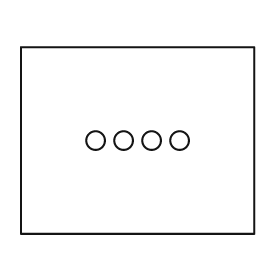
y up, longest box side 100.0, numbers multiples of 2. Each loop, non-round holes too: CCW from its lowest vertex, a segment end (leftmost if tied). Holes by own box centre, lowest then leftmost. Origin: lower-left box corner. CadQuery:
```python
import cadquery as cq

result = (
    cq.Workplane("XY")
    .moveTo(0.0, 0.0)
    .lineTo(100.0, 0.0)
    .lineTo(100.0, 80.0)
    .lineTo(0.0, 80.0)
    .close()
    .moveTo(32.0, 40.0)
    .circle(4.0)
    .moveTo(44.0, 40.0)
    .circle(4.0)
    .moveTo(56.0, 40.0)
    .circle(4.0)
    .moveTo(68.0, 40.0)
    .circle(4.0)
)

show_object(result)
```